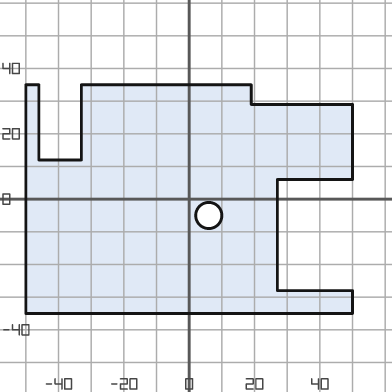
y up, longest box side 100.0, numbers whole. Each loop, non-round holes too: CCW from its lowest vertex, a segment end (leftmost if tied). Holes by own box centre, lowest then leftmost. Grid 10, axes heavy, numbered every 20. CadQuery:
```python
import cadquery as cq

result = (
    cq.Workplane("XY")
    .moveTo(-50.0, -35.0)
    .lineTo(50.0, -35.0)
    .lineTo(50.0, -28.0)
    .lineTo(27.0, -28.0)
    .lineTo(27.0, 6.0)
    .lineTo(50.0, 6.0)
    .lineTo(50.0, 29.0)
    .lineTo(19.0, 29.0)
    .lineTo(19.0, 35.0)
    .lineTo(-33.0, 35.0)
    .lineTo(-33.0, 12.0)
    .lineTo(-46.0, 12.0)
    .lineTo(-46.0, 35.0)
    .lineTo(-50.0, 35.0)
    .close()
    .moveTo(6.0, -5.0)
    .circle(4.0)
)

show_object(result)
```